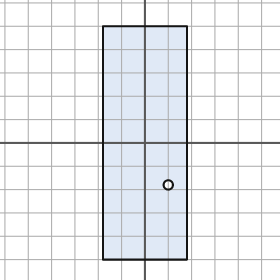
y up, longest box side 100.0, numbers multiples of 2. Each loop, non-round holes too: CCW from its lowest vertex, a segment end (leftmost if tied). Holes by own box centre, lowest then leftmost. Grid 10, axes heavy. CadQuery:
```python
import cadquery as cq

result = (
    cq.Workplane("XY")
    .moveTo(-18.0, -50.0)
    .lineTo(18.0, -50.0)
    .lineTo(18.0, 50.0)
    .lineTo(-18.0, 50.0)
    .close()
    .moveTo(10.0, -18.0)
    .circle(2.0)
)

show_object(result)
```